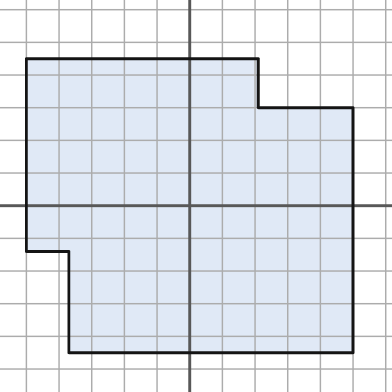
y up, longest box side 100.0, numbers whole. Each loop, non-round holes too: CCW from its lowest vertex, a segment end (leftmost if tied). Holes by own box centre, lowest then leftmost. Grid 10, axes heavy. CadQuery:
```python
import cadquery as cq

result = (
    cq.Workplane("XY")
    .moveTo(-37.0, -45.0)
    .lineTo(50.0, -45.0)
    .lineTo(50.0, 30.0)
    .lineTo(21.0, 30.0)
    .lineTo(21.0, 45.0)
    .lineTo(-50.0, 45.0)
    .lineTo(-50.0, -14.0)
    .lineTo(-37.0, -14.0)
    .close()
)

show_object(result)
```